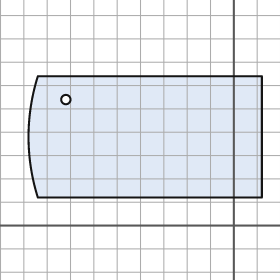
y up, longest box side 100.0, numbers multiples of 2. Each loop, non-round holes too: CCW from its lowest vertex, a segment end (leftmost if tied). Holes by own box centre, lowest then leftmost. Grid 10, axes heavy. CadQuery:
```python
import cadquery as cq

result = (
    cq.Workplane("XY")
    .moveTo(-84.0, 12.0)
    .lineTo(12.0, 12.0)
    .lineTo(12.0, 64.0)
    .lineTo(-84.0, 64.0)
    .threePointArc((-88.0, 38.0), (-84.0, 12.0))
    .close()
    .moveTo(-72.0, 54.0)
    .circle(2.0)
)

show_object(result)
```